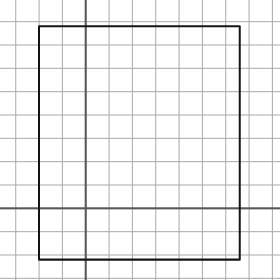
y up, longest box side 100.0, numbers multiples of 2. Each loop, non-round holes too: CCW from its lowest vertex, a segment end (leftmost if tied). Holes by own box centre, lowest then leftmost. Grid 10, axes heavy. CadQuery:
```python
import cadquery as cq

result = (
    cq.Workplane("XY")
    .moveTo(-20.0, -22.0)
    .lineTo(66.0, -22.0)
    .lineTo(66.0, 78.0)
    .lineTo(-20.0, 78.0)
    .close()
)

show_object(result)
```